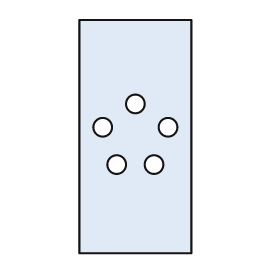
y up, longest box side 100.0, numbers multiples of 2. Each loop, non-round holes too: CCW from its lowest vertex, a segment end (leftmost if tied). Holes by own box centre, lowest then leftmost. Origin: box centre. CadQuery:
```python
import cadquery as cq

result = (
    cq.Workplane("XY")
    .moveTo(-24.0, -50.0)
    .lineTo(24.0, -50.0)
    .lineTo(24.0, 50.0)
    .lineTo(-24.0, 50.0)
    .close()
    .moveTo(-8.0, -12.0)
    .circle(4.0)
    .moveTo(8.0, -12.0)
    .circle(4.0)
    .moveTo(-14.0, 4.0)
    .circle(4.0)
    .moveTo(14.0, 4.0)
    .circle(4.0)
    .moveTo(0.0, 14.0)
    .circle(4.0)
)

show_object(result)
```